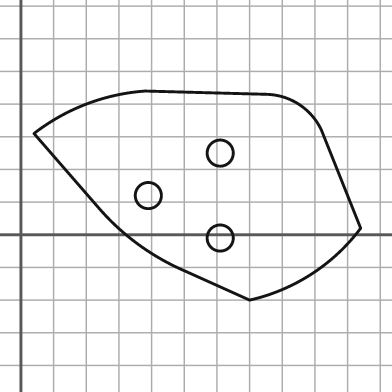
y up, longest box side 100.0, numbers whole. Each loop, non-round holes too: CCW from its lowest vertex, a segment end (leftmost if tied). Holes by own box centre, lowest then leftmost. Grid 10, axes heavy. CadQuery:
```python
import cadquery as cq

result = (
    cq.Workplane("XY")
    .moveTo(70.0, -20.0)
    .threePointArc((89.0, -12.0), (104.0, 2.0))
    .lineTo(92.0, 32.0)
    .threePointArc((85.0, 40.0), (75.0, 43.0))
    .lineTo(38.0, 44.0)
    .threePointArc((20.0, 40.0), (4.0, 31.0))
    .lineTo(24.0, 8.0)
    .threePointArc((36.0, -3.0), (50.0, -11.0))
    .close()
    .moveTo(61.0, -1.0)
    .circle(4.0)
    .moveTo(39.0, 12.0)
    .circle(4.0)
    .moveTo(61.0, 25.0)
    .circle(4.0)
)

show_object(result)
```